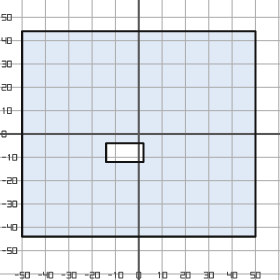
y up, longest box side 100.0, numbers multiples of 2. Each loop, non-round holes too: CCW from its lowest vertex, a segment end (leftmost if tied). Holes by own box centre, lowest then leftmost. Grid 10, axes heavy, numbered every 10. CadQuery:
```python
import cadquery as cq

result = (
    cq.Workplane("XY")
    .moveTo(-50.0, -44.0)
    .lineTo(50.0, -44.0)
    .lineTo(50.0, 44.0)
    .lineTo(-50.0, 44.0)
    .close()
    .moveTo(-14.0, -12.0)
    .lineTo(2.0, -12.0)
    .lineTo(2.0, -4.0)
    .lineTo(-14.0, -4.0)
    .close()
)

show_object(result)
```